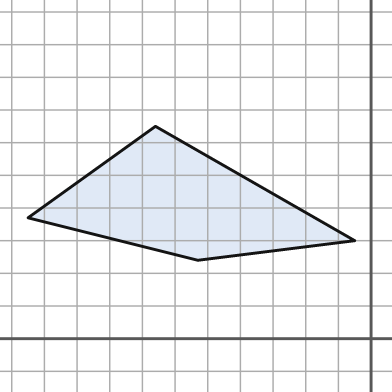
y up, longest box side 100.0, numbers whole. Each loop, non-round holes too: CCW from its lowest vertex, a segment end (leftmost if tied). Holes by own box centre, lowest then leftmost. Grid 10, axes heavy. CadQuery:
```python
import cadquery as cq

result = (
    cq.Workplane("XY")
    .moveTo(-53.0, 24.0)
    .lineTo(-5.0, 30.0)
    .lineTo(-66.0, 65.0)
    .lineTo(-105.0, 37.0)
    .close()
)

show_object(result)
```